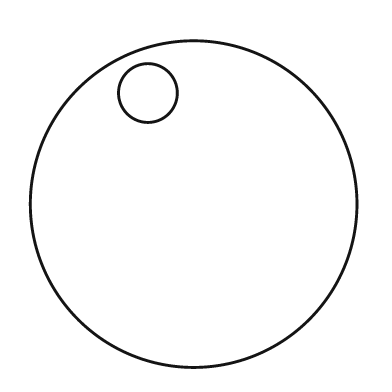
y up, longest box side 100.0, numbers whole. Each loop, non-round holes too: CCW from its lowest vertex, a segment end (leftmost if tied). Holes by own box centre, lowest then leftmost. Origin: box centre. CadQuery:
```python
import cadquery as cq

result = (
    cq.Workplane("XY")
    .moveTo(0.0, 0.0)
    .circle(50.0)
    .moveTo(-14.0, 34.0)
    .circle(9.0)
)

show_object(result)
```